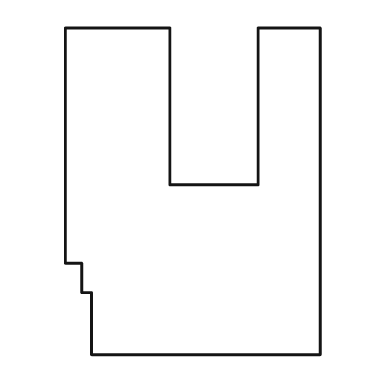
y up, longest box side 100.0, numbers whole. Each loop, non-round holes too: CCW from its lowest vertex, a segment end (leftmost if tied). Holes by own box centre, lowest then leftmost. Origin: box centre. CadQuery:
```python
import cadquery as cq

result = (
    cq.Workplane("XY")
    .moveTo(-31.0, -50.0)
    .lineTo(39.0, -50.0)
    .lineTo(39.0, 50.0)
    .lineTo(20.0, 50.0)
    .lineTo(20.0, 2.0)
    .lineTo(-7.0, 2.0)
    .lineTo(-7.0, 50.0)
    .lineTo(-39.0, 50.0)
    .lineTo(-39.0, -22.0)
    .lineTo(-34.0, -22.0)
    .lineTo(-34.0, -31.0)
    .lineTo(-31.0, -31.0)
    .close()
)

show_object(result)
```